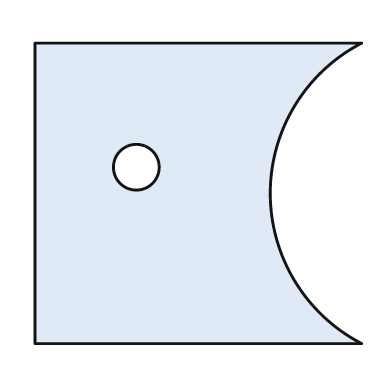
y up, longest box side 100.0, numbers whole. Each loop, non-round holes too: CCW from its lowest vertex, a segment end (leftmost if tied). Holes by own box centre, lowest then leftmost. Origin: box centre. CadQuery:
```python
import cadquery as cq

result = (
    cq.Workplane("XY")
    .moveTo(-50.0, -46.0)
    .lineTo(50.0, -46.0)
    .threePointArc((22.0, 0.0), (50.0, 46.0))
    .lineTo(-50.0, 46.0)
    .close()
    .moveTo(-19.0, 8.0)
    .circle(7.0)
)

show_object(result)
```